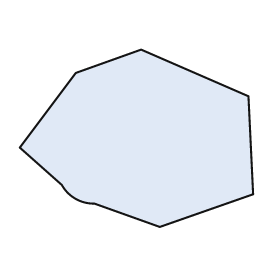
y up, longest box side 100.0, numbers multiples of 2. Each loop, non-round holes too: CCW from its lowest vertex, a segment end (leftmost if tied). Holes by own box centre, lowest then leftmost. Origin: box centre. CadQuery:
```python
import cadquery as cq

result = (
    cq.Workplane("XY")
    .moveTo(10.0, -38.0)
    .lineTo(50.0, -24.0)
    .lineTo(48.0, 18.0)
    .lineTo(2.0, 38.0)
    .lineTo(-26.0, 28.0)
    .lineTo(-50.0, -4.0)
    .lineTo(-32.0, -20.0)
    .threePointArc((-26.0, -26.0), (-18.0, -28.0))
    .close()
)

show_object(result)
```